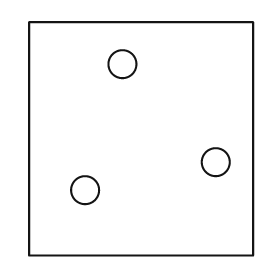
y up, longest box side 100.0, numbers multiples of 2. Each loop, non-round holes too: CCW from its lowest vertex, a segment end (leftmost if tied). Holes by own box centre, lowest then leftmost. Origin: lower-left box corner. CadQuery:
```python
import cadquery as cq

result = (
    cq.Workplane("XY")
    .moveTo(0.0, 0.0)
    .lineTo(96.0, 0.0)
    .lineTo(96.0, 100.0)
    .lineTo(0.0, 100.0)
    .close()
    .moveTo(24.0, 28.0)
    .circle(6.0)
    .moveTo(80.0, 40.0)
    .circle(6.0)
    .moveTo(40.0, 82.0)
    .circle(6.0)
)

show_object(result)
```